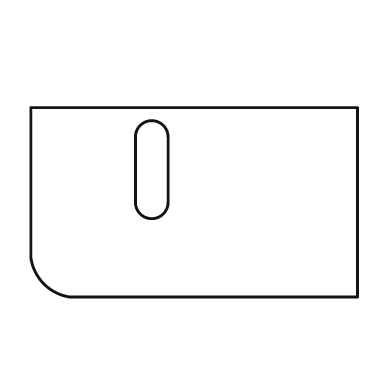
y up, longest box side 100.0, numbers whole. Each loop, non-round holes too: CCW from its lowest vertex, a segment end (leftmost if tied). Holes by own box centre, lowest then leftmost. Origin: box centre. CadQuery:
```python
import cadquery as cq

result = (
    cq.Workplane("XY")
    .moveTo(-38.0, -29.0)
    .lineTo(50.0, -29.0)
    .lineTo(50.0, 29.0)
    .lineTo(-50.0, 29.0)
    .lineTo(-50.0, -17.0)
    .threePointArc((-46.0, -25.0), (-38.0, -29.0))
    .close()
    .moveTo(-18.0, 0.0)
    .threePointArc((-13.0, -5.0), (-8.0, 0.0))
    .lineTo(-8.0, 20.0)
    .threePointArc((-13.0, 25.0), (-18.0, 20.0))
    .close()
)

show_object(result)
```